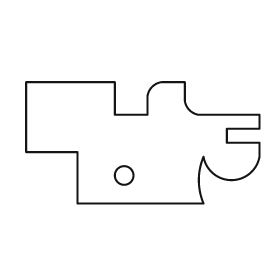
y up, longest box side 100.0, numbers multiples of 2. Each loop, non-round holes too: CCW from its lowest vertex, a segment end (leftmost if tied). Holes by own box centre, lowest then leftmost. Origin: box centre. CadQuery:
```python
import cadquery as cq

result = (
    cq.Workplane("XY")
    .moveTo(-28.0, -26.0)
    .lineTo(26.0, -26.0)
    .threePointArc((24.0, -16.0), (26.0, -6.0))
    .threePointArc((38.0, -16.0), (50.0, -6.0))
    .lineTo(50.0, 0.0)
    .lineTo(36.0, 0.0)
    .lineTo(36.0, 6.0)
    .lineTo(50.0, 6.0)
    .lineTo(50.0, 12.0)
    .lineTo(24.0, 12.0)
    .threePointArc((20.0, 14.0), (18.0, 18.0))
    .lineTo(18.0, 26.0)
    .lineTo(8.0, 26.0)
    .threePointArc((4.0, 24.0), (2.0, 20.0))
    .lineTo(2.0, 12.0)
    .lineTo(-12.0, 12.0)
    .lineTo(-12.0, 26.0)
    .lineTo(-50.0, 26.0)
    .lineTo(-50.0, -4.0)
    .lineTo(-28.0, -4.0)
    .close()
    .moveTo(-8.0, -14.0)
    .circle(4.0)
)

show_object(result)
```